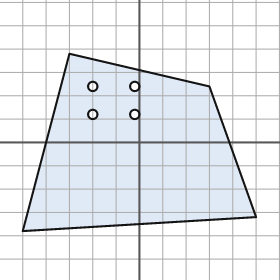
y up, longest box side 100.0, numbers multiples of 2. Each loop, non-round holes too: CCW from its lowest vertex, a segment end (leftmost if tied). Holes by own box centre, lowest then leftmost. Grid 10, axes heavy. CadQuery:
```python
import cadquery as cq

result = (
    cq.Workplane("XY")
    .moveTo(-50.0, -38.0)
    .lineTo(50.0, -32.0)
    .lineTo(30.0, 24.0)
    .lineTo(-30.0, 38.0)
    .close()
    .moveTo(-20.0, 12.0)
    .circle(2.0)
    .moveTo(-2.0, 12.0)
    .circle(2.0)
    .moveTo(-20.0, 24.0)
    .circle(2.0)
    .moveTo(-2.0, 24.0)
    .circle(2.0)
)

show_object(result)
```